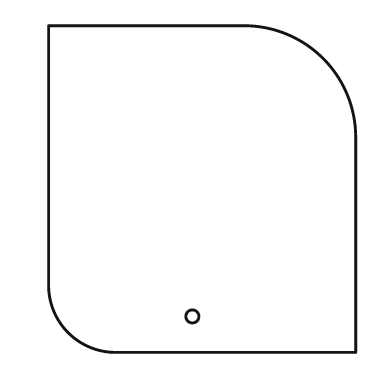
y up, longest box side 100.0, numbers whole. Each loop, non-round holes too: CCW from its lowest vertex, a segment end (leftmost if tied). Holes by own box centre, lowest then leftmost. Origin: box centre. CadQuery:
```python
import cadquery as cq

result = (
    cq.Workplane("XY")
    .moveTo(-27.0, -50.0)
    .lineTo(47.0, -50.0)
    .lineTo(47.0, 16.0)
    .threePointArc((37.0, 40.0), (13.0, 50.0))
    .lineTo(-47.0, 50.0)
    .lineTo(-47.0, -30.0)
    .threePointArc((-41.0, -44.0), (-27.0, -50.0))
    .close()
    .moveTo(-3.0, -39.0)
    .circle(2.0)
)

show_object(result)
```